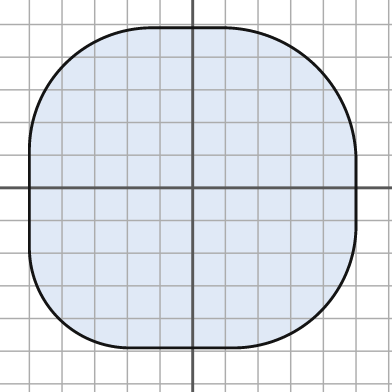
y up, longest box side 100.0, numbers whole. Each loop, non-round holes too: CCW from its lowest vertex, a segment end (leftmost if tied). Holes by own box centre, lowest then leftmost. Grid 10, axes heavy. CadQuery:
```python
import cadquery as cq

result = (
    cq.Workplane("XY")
    .moveTo(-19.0, -49.0)
    .lineTo(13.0, -49.0)
    .threePointArc((39.0, -38.0), (50.0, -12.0))
    .lineTo(50.0, 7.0)
    .threePointArc((38.0, 37.0), (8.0, 49.0))
    .lineTo(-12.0, 49.0)
    .threePointArc((-39.0, 38.0), (-50.0, 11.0))
    .lineTo(-50.0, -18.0)
    .threePointArc((-41.0, -40.0), (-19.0, -49.0))
    .close()
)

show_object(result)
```